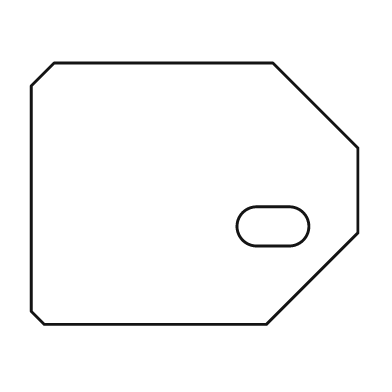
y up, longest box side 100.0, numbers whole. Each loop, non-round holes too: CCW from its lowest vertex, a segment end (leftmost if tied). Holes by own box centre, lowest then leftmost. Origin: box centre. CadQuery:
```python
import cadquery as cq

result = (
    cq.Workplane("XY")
    .moveTo(-46.0, -40.0)
    .lineTo(22.0, -40.0)
    .lineTo(50.0, -12.0)
    .lineTo(50.0, 14.0)
    .lineTo(24.0, 40.0)
    .lineTo(-43.0, 40.0)
    .lineTo(-50.0, 33.0)
    .lineTo(-50.0, -36.0)
    .close()
    .moveTo(19.0, -16.0)
    .lineTo(29.0, -16.0)
    .threePointArc((35.0, -10.0), (29.0, -4.0))
    .lineTo(19.0, -4.0)
    .threePointArc((13.0, -10.0), (19.0, -16.0))
    .close()
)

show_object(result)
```